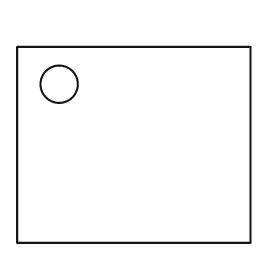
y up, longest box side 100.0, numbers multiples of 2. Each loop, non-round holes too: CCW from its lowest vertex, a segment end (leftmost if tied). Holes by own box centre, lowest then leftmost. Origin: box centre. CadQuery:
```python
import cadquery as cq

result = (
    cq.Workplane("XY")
    .moveTo(-50.0, -42.0)
    .lineTo(50.0, -42.0)
    .lineTo(50.0, 42.0)
    .lineTo(-50.0, 42.0)
    .close()
    .moveTo(-32.0, 26.0)
    .circle(8.0)
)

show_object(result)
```